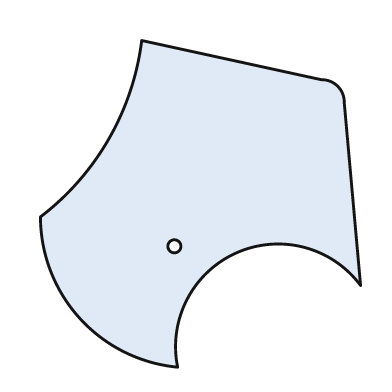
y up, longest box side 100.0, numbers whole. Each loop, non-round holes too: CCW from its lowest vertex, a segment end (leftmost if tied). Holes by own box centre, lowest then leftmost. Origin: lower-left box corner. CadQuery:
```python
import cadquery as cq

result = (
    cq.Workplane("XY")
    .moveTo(42.0, 0.0)
    .threePointArc((60.0, 35.0), (98.0, 25.0))
    .lineTo(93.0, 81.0)
    .threePointArc((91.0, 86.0), (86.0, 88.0))
    .lineTo(31.0, 100.0)
    .threePointArc((21.0, 70.0), (0.0, 46.0))
    .threePointArc((12.0, 15.0), (42.0, 0.0))
    .close()
    .moveTo(41.0, 37.0)
    .circle(2.0)
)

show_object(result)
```